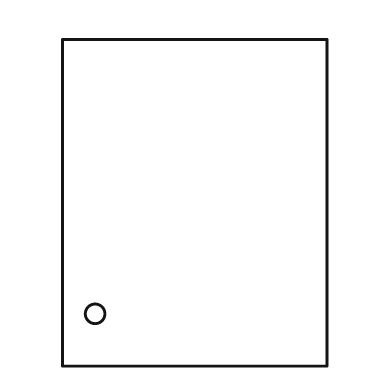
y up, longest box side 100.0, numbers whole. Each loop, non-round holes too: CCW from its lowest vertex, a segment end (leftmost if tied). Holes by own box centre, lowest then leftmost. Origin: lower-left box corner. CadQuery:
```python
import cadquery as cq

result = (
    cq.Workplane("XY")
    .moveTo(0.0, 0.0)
    .lineTo(81.0, 0.0)
    .lineTo(81.0, 100.0)
    .lineTo(0.0, 100.0)
    .close()
    .moveTo(10.0, 16.0)
    .circle(3.0)
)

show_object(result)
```